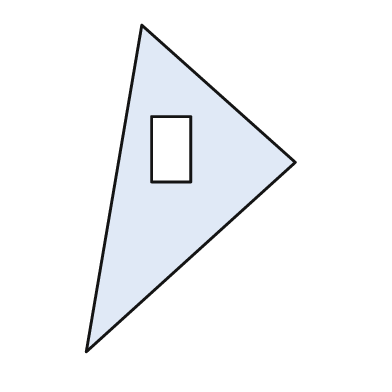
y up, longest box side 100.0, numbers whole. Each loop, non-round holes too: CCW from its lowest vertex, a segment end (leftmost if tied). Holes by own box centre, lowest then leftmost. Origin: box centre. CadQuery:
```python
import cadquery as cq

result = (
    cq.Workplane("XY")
    .moveTo(-32.0, -50.0)
    .lineTo(32.0, 8.0)
    .lineTo(-15.0, 50.0)
    .close()
    .moveTo(-12.0, 2.0)
    .lineTo(0.0, 2.0)
    .lineTo(0.0, 22.0)
    .lineTo(-12.0, 22.0)
    .close()
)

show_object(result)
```